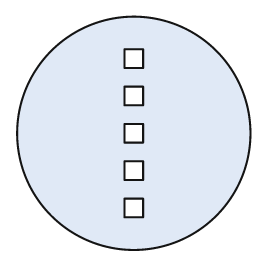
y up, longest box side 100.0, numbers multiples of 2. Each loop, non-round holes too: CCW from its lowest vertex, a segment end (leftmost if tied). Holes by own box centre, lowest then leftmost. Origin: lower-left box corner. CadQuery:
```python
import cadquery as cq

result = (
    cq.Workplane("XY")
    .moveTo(50.0, 50.0)
    .circle(50.0)
    .moveTo(46.0, 14.0)
    .lineTo(54.0, 14.0)
    .lineTo(54.0, 22.0)
    .lineTo(46.0, 22.0)
    .close()
    .moveTo(46.0, 30.0)
    .lineTo(54.0, 30.0)
    .lineTo(54.0, 38.0)
    .lineTo(46.0, 38.0)
    .close()
    .moveTo(46.0, 46.0)
    .lineTo(54.0, 46.0)
    .lineTo(54.0, 54.0)
    .lineTo(46.0, 54.0)
    .close()
    .moveTo(46.0, 62.0)
    .lineTo(54.0, 62.0)
    .lineTo(54.0, 70.0)
    .lineTo(46.0, 70.0)
    .close()
    .moveTo(46.0, 78.0)
    .lineTo(54.0, 78.0)
    .lineTo(54.0, 86.0)
    .lineTo(46.0, 86.0)
    .close()
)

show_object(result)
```